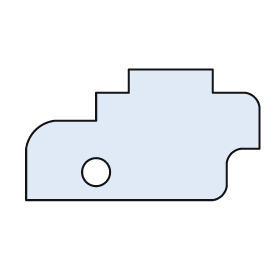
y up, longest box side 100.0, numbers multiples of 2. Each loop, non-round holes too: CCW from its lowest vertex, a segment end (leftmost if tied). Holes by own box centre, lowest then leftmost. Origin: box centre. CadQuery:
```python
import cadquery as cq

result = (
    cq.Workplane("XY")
    .moveTo(-50.0, -28.0)
    .lineTo(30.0, -28.0)
    .threePointArc((34.0, -26.0), (36.0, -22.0))
    .lineTo(36.0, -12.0)
    .threePointArc((38.0, -8.0), (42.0, -6.0))
    .lineTo(50.0, -6.0)
    .lineTo(50.0, 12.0)
    .threePointArc((48.0, 16.0), (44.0, 18.0))
    .lineTo(30.0, 18.0)
    .lineTo(30.0, 28.0)
    .lineTo(-6.0, 28.0)
    .lineTo(-6.0, 18.0)
    .lineTo(-20.0, 18.0)
    .lineTo(-20.0, 6.0)
    .lineTo(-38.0, 6.0)
    .threePointArc((-46.0, 2.0), (-50.0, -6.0))
    .close()
    .moveTo(-20.0, -16.0)
    .circle(6.0)
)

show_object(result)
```